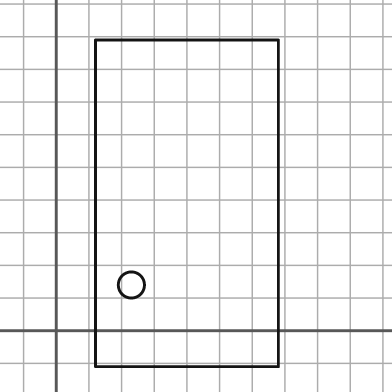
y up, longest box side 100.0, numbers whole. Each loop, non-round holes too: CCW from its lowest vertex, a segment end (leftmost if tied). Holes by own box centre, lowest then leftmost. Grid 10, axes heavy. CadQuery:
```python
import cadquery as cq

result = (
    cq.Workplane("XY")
    .moveTo(12.0, -11.0)
    .lineTo(68.0, -11.0)
    .lineTo(68.0, 89.0)
    .lineTo(12.0, 89.0)
    .close()
    .moveTo(23.0, 14.0)
    .circle(4.0)
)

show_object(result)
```